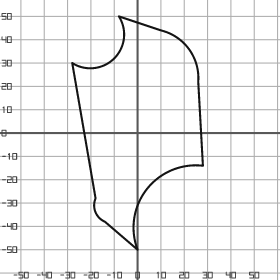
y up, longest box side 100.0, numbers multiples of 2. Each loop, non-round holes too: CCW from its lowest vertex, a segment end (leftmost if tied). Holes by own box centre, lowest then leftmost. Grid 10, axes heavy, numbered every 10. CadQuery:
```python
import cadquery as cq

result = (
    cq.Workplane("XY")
    .moveTo(0.0, -50.0)
    .threePointArc((4.0, -24.0), (28.0, -14.0))
    .lineTo(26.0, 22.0)
    .threePointArc((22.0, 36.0), (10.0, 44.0))
    .lineTo(-8.0, 50.0)
    .threePointArc((-10.0, 32.0), (-28.0, 30.0))
    .lineTo(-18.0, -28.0)
    .threePointArc((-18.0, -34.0), (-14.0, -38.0))
    .close()
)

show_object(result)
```